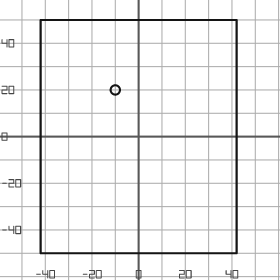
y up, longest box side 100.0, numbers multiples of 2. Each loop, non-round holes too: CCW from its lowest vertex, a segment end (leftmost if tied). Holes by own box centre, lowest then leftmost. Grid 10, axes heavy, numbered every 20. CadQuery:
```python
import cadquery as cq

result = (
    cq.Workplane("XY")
    .moveTo(-42.0, -50.0)
    .lineTo(42.0, -50.0)
    .lineTo(42.0, 50.0)
    .lineTo(-42.0, 50.0)
    .close()
    .moveTo(-10.0, 20.0)
    .circle(2.0)
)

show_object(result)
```